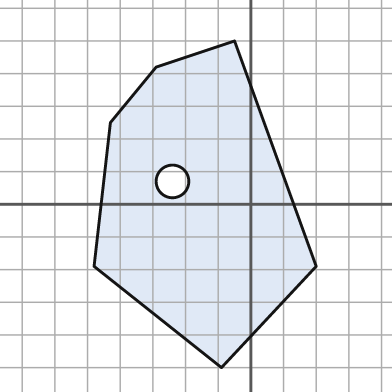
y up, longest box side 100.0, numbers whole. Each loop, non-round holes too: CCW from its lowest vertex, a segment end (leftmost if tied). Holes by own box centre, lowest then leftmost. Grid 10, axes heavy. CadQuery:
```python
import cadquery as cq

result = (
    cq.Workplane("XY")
    .moveTo(-9.0, -50.0)
    .lineTo(20.0, -19.0)
    .lineTo(-5.0, 50.0)
    .lineTo(-29.0, 42.0)
    .lineTo(-43.0, 25.0)
    .lineTo(-48.0, -19.0)
    .close()
    .moveTo(-24.0, 7.0)
    .circle(5.0)
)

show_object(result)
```